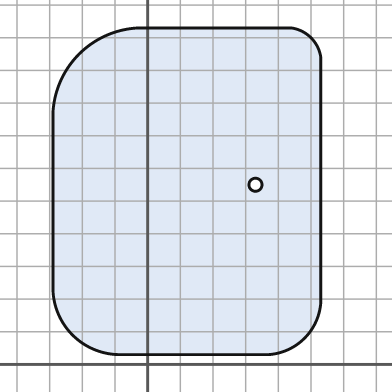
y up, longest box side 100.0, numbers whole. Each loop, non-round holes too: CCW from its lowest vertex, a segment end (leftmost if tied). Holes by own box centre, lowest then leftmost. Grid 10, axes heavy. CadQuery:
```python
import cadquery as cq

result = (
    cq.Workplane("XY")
    .moveTo(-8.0, 3.0)
    .lineTo(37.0, 3.0)
    .threePointArc((48.0, 8.0), (53.0, 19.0))
    .lineTo(53.0, 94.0)
    .threePointArc((50.0, 100.0), (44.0, 103.0))
    .lineTo(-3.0, 103.0)
    .threePointArc((-21.0, 95.0), (-29.0, 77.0))
    .lineTo(-29.0, 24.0)
    .threePointArc((-23.0, 9.0), (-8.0, 3.0))
    .close()
    .moveTo(33.0, 55.0)
    .circle(2.0)
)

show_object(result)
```